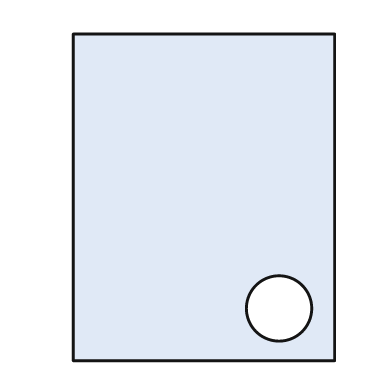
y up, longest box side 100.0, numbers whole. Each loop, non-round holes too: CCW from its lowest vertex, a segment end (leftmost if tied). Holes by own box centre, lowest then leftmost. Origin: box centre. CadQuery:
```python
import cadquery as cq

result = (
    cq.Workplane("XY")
    .moveTo(-40.0, -50.0)
    .lineTo(40.0, -50.0)
    .lineTo(40.0, 50.0)
    .lineTo(-40.0, 50.0)
    .close()
    .moveTo(23.0, -34.0)
    .circle(10.0)
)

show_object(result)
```